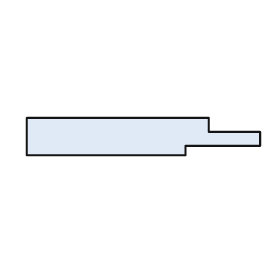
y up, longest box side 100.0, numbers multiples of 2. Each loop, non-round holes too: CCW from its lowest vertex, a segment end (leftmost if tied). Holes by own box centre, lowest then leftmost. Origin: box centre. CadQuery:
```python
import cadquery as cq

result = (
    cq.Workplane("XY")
    .moveTo(-50.0, -8.0)
    .lineTo(18.0, -8.0)
    .lineTo(18.0, -4.0)
    .lineTo(50.0, -4.0)
    .lineTo(50.0, 2.0)
    .lineTo(28.0, 2.0)
    .lineTo(28.0, 8.0)
    .lineTo(-50.0, 8.0)
    .close()
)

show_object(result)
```